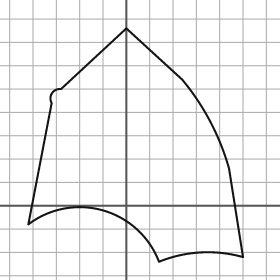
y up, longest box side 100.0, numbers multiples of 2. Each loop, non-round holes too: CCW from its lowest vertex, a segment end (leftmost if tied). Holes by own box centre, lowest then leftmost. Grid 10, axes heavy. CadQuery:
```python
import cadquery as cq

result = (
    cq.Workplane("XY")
    .moveTo(14.0, -24.0)
    .threePointArc((32.0, -20.0), (50.0, -22.0))
    .lineTo(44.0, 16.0)
    .threePointArc((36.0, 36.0), (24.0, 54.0))
    .lineTo(0.0, 76.0)
    .lineTo(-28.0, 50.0)
    .threePointArc((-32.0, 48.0), (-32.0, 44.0))
    .lineTo(-42.0, -8.0)
    .threePointArc((-10.0, -2.0), (14.0, -24.0))
    .close()
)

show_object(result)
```